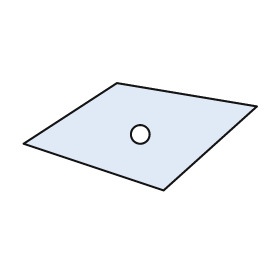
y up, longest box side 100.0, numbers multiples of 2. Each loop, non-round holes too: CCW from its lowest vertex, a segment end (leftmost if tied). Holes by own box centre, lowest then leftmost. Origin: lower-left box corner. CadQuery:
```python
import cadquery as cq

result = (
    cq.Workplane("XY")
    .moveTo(60.0, 0.0)
    .lineTo(100.0, 36.0)
    .lineTo(40.0, 46.0)
    .lineTo(0.0, 20.0)
    .close()
    .moveTo(50.0, 24.0)
    .circle(4.0)
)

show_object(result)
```